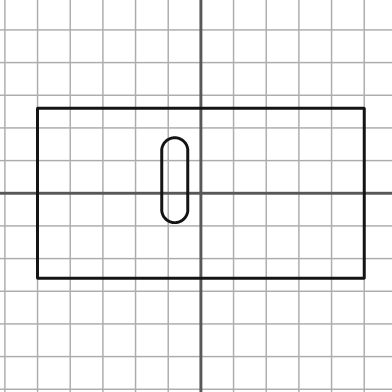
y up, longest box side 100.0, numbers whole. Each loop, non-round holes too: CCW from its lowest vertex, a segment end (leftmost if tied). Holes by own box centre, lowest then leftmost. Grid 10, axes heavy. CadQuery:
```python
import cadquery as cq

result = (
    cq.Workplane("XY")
    .moveTo(-50.0, -26.0)
    .lineTo(50.0, -26.0)
    .lineTo(50.0, 26.0)
    .lineTo(-50.0, 26.0)
    .close()
    .moveTo(-12.0, -5.0)
    .threePointArc((-8.0, -9.0), (-4.0, -5.0))
    .lineTo(-4.0, 13.0)
    .threePointArc((-8.0, 17.0), (-12.0, 13.0))
    .close()
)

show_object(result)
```